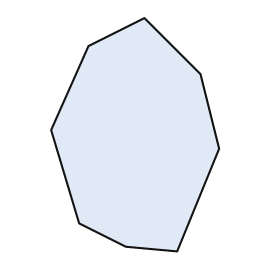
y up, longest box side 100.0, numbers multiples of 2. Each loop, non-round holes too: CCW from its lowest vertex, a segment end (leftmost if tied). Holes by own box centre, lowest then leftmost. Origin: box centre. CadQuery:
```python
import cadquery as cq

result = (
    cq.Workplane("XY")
    .moveTo(18.0, -50.0)
    .lineTo(36.0, -6.0)
    .lineTo(28.0, 26.0)
    .lineTo(4.0, 50.0)
    .lineTo(-20.0, 38.0)
    .lineTo(-36.0, 2.0)
    .lineTo(-24.0, -38.0)
    .lineTo(-4.0, -48.0)
    .close()
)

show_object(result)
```